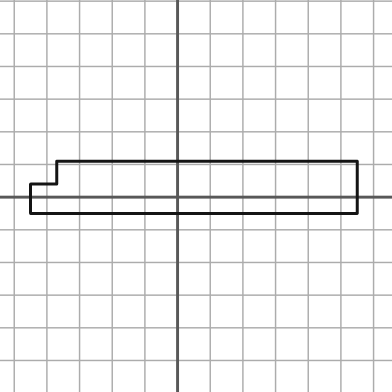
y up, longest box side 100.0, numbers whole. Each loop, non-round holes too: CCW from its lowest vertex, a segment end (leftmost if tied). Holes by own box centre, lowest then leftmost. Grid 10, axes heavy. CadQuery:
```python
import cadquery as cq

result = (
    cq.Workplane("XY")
    .moveTo(-45.0, -5.0)
    .lineTo(55.0, -5.0)
    .lineTo(55.0, 11.0)
    .lineTo(-37.0, 11.0)
    .lineTo(-37.0, 4.0)
    .lineTo(-45.0, 4.0)
    .close()
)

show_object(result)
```